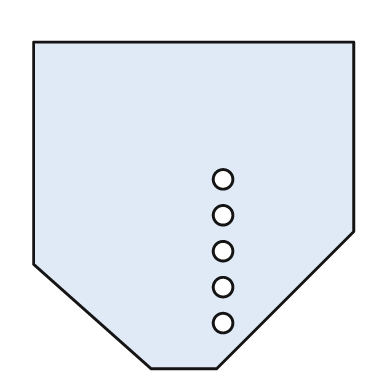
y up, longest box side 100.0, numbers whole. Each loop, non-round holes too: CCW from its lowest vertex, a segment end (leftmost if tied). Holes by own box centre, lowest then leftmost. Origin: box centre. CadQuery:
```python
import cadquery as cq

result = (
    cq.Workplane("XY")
    .moveTo(-13.0, -50.0)
    .lineTo(7.0, -50.0)
    .lineTo(49.0, -8.0)
    .lineTo(49.0, 50.0)
    .lineTo(-49.0, 50.0)
    .lineTo(-49.0, -18.0)
    .close()
    .moveTo(9.0, -36.0)
    .circle(3.0)
    .moveTo(9.0, -25.0)
    .circle(3.0)
    .moveTo(9.0, -14.0)
    .circle(3.0)
    .moveTo(9.0, -3.0)
    .circle(3.0)
    .moveTo(9.0, 8.0)
    .circle(3.0)
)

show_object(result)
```